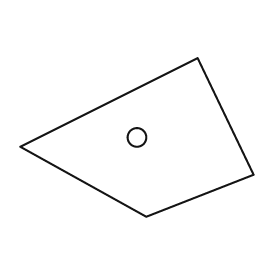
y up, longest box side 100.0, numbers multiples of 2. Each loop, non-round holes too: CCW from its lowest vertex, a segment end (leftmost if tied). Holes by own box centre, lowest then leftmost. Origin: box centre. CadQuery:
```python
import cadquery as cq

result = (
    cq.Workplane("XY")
    .moveTo(4.0, -34.0)
    .lineTo(50.0, -16.0)
    .lineTo(26.0, 34.0)
    .lineTo(-50.0, -4.0)
    .close()
    .moveTo(0.0, 0.0)
    .circle(4.0)
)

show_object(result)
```